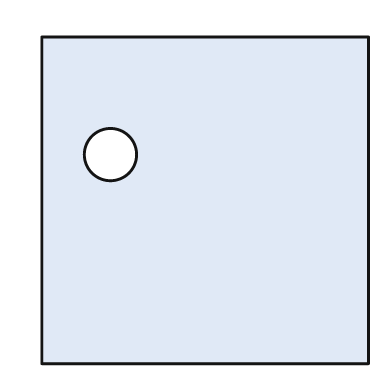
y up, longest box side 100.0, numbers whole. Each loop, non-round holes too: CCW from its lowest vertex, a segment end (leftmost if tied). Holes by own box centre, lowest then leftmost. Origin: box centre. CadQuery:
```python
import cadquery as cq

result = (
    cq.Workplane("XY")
    .moveTo(-50.0, -50.0)
    .lineTo(50.0, -50.0)
    .lineTo(50.0, 50.0)
    .lineTo(-50.0, 50.0)
    .close()
    .moveTo(-29.0, 14.0)
    .circle(8.0)
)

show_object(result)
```